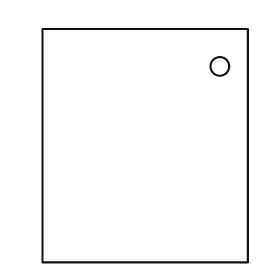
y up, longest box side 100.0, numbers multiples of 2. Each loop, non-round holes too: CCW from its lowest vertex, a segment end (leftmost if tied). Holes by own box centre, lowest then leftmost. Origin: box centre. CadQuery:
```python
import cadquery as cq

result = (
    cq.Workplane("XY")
    .moveTo(-44.0, -50.0)
    .lineTo(44.0, -50.0)
    .lineTo(44.0, 50.0)
    .lineTo(-44.0, 50.0)
    .close()
    .moveTo(32.0, 34.0)
    .circle(4.0)
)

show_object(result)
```